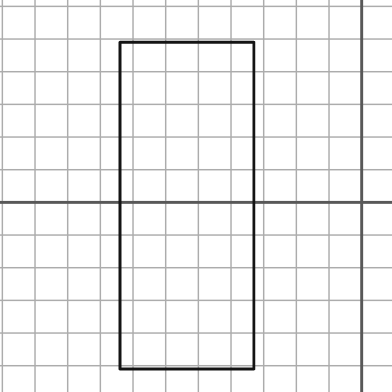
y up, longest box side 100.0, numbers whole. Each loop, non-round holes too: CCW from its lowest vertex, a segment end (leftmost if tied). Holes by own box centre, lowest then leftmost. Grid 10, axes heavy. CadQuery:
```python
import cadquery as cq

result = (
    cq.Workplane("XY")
    .moveTo(-74.0, -51.0)
    .lineTo(-33.0, -51.0)
    .lineTo(-33.0, 49.0)
    .lineTo(-74.0, 49.0)
    .close()
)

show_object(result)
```